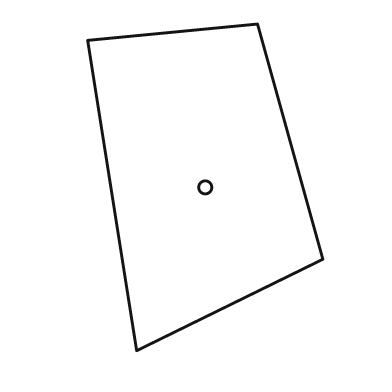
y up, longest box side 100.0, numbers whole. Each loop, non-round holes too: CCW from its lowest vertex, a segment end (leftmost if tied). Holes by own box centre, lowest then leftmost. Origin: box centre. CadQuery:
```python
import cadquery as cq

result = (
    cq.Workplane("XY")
    .moveTo(-21.0, -50.0)
    .lineTo(36.0, -22.0)
    .lineTo(16.0, 50.0)
    .lineTo(-36.0, 45.0)
    .close()
    .moveTo(0.0, 0.0)
    .circle(2.0)
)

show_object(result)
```